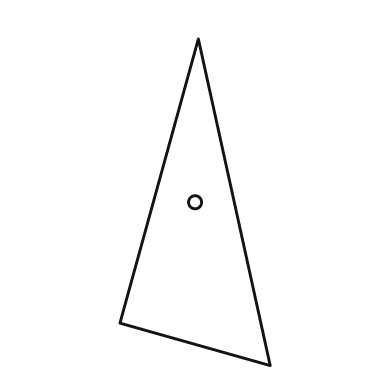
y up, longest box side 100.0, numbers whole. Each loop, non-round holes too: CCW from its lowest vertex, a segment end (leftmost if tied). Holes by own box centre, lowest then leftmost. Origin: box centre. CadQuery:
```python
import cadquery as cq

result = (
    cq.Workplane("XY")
    .moveTo(23.0, -50.0)
    .lineTo(1.0, 50.0)
    .lineTo(-23.0, -37.0)
    .close()
    .moveTo(0.0, 0.0)
    .circle(2.0)
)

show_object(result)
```